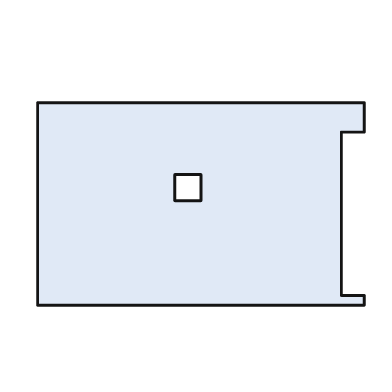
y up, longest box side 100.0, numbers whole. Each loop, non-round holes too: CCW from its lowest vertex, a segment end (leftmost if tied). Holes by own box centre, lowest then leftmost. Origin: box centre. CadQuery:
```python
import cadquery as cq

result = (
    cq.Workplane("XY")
    .moveTo(-50.0, -31.0)
    .lineTo(50.0, -31.0)
    .lineTo(50.0, -28.0)
    .lineTo(43.0, -28.0)
    .lineTo(43.0, 22.0)
    .lineTo(50.0, 22.0)
    .lineTo(50.0, 31.0)
    .lineTo(-50.0, 31.0)
    .close()
    .moveTo(-8.0, 1.0)
    .lineTo(0.0, 1.0)
    .lineTo(0.0, 9.0)
    .lineTo(-8.0, 9.0)
    .close()
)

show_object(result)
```